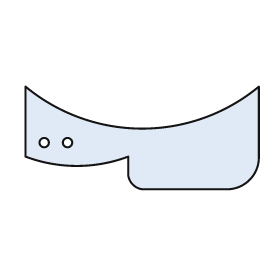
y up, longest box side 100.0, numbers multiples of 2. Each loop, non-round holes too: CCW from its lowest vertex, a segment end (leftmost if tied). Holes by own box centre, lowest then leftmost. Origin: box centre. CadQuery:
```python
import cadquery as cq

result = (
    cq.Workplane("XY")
    .moveTo(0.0, -22.0)
    .lineTo(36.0, -22.0)
    .threePointArc((46.0, -18.0), (50.0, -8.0))
    .lineTo(50.0, 22.0)
    .threePointArc((0.0, 4.0), (-50.0, 22.0))
    .lineTo(-50.0, -8.0)
    .threePointArc((-28.0, -12.0), (-6.0, -8.0))
    .lineTo(-6.0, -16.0)
    .threePointArc((-4.0, -20.0), (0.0, -22.0))
    .close()
    .moveTo(-42.0, -2.0)
    .circle(2.0)
    .moveTo(-32.0, -2.0)
    .circle(2.0)
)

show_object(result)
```